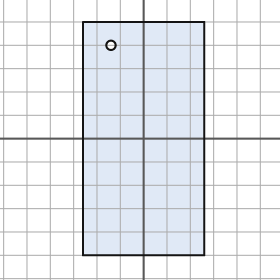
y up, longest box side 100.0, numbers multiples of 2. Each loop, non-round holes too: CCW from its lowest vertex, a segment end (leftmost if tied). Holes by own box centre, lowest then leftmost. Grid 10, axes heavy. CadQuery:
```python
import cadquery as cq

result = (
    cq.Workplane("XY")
    .moveTo(-26.0, -50.0)
    .lineTo(26.0, -50.0)
    .lineTo(26.0, 50.0)
    .lineTo(-26.0, 50.0)
    .close()
    .moveTo(-14.0, 40.0)
    .circle(2.0)
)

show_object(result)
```